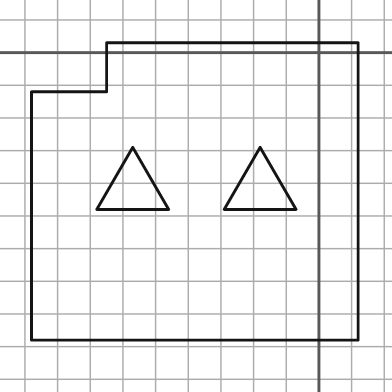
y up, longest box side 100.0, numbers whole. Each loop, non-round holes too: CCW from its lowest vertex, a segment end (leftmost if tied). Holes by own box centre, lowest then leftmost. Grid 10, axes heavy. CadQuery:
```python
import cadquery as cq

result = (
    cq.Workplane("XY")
    .moveTo(-88.0, -88.0)
    .lineTo(12.0, -88.0)
    .lineTo(12.0, 3.0)
    .lineTo(-65.0, 3.0)
    .lineTo(-65.0, -12.0)
    .lineTo(-88.0, -12.0)
    .close()
    .moveTo(-68.0, -48.0)
    .lineTo(-46.0, -48.0)
    .lineTo(-57.0, -29.0)
    .close()
    .moveTo(-29.0, -48.0)
    .lineTo(-7.0, -48.0)
    .lineTo(-18.0, -29.0)
    .close()
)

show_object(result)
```